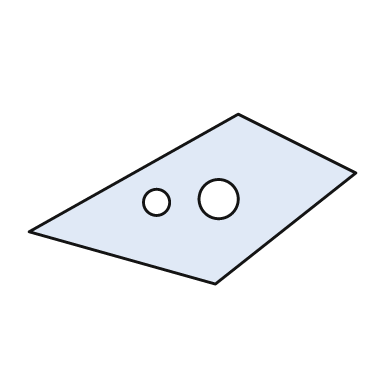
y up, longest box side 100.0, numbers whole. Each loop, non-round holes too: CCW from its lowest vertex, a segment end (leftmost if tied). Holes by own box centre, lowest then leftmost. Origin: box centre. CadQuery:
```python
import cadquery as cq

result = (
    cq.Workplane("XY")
    .moveTo(7.0, -26.0)
    .lineTo(50.0, 8.0)
    .lineTo(14.0, 26.0)
    .lineTo(-50.0, -10.0)
    .close()
    .moveTo(-11.0, -1.0)
    .circle(4.0)
    .moveTo(8.0, 0.0)
    .circle(6.0)
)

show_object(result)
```